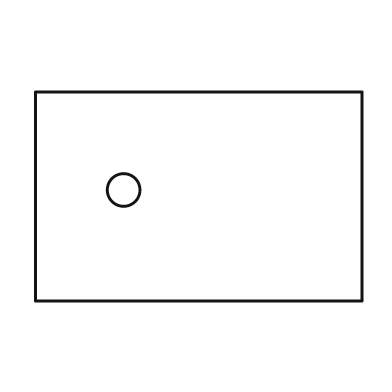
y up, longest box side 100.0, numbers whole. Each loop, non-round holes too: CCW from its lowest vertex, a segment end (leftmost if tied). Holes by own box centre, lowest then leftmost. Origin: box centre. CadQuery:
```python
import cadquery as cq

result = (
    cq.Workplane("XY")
    .moveTo(-50.0, -32.0)
    .lineTo(50.0, -32.0)
    .lineTo(50.0, 32.0)
    .lineTo(-50.0, 32.0)
    .close()
    .moveTo(-23.0, 2.0)
    .circle(5.0)
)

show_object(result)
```